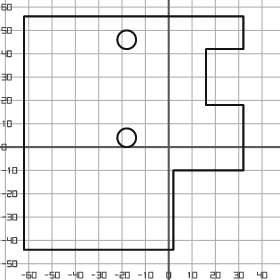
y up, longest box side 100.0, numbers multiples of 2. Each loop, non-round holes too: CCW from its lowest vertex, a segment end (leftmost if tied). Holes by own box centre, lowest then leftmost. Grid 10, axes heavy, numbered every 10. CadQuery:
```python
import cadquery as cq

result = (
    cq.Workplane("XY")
    .moveTo(-62.0, -44.0)
    .lineTo(2.0, -44.0)
    .lineTo(2.0, -10.0)
    .lineTo(32.0, -10.0)
    .lineTo(32.0, 18.0)
    .lineTo(16.0, 18.0)
    .lineTo(16.0, 42.0)
    .lineTo(32.0, 42.0)
    .lineTo(32.0, 56.0)
    .lineTo(-62.0, 56.0)
    .close()
    .moveTo(-18.0, 4.0)
    .circle(4.0)
    .moveTo(-18.0, 46.0)
    .circle(4.0)
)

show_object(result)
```